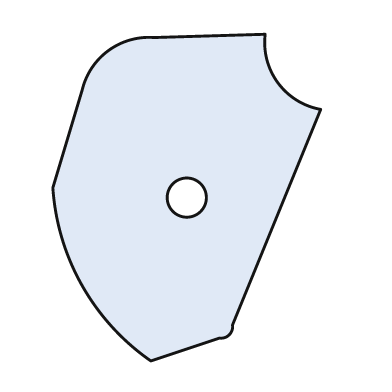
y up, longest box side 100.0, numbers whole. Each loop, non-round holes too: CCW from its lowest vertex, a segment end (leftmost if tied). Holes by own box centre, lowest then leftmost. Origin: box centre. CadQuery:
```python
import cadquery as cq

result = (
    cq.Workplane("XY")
    .moveTo(-11.0, -50.0)
    .lineTo(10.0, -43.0)
    .threePointArc((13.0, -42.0), (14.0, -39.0))
    .lineTo(41.0, 27.0)
    .threePointArc((28.0, 35.0), (24.0, 50.0))
    .lineTo(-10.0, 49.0)
    .threePointArc((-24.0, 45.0), (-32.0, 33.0))
    .lineTo(-41.0, 3.0)
    .threePointArc((-32.0, -27.0), (-11.0, -50.0))
    .close()
    .moveTo(0.0, 0.0)
    .circle(6.0)
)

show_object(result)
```